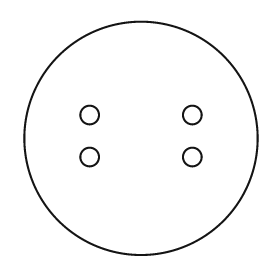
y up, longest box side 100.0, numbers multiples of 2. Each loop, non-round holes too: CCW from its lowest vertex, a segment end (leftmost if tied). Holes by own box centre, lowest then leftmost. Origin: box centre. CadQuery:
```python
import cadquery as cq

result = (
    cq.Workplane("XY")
    .moveTo(0.0, 0.0)
    .circle(50.0)
    .moveTo(-22.0, -8.0)
    .circle(4.0)
    .moveTo(22.0, -8.0)
    .circle(4.0)
    .moveTo(-22.0, 10.0)
    .circle(4.0)
    .moveTo(22.0, 10.0)
    .circle(4.0)
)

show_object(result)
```